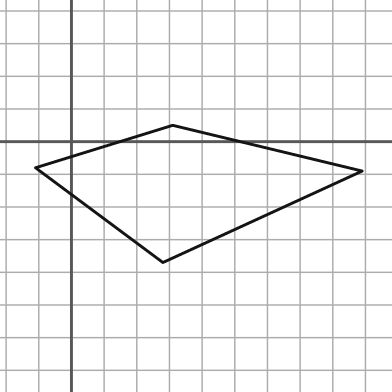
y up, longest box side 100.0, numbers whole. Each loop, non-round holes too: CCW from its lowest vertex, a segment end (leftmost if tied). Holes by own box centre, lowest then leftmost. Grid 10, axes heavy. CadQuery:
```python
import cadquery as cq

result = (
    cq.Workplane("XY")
    .moveTo(28.0, -37.0)
    .lineTo(89.0, -9.0)
    .lineTo(31.0, 5.0)
    .lineTo(-11.0, -8.0)
    .close()
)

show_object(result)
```